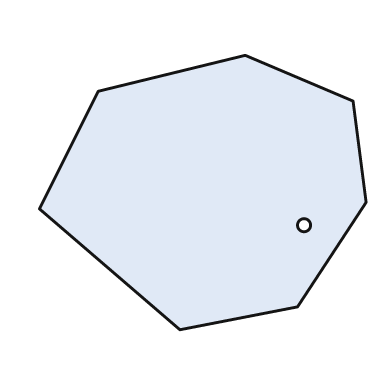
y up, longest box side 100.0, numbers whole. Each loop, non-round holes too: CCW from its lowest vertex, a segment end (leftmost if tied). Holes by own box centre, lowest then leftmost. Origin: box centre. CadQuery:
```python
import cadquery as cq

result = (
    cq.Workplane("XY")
    .moveTo(-7.0, -42.0)
    .lineTo(29.0, -35.0)
    .lineTo(50.0, -3.0)
    .lineTo(46.0, 28.0)
    .lineTo(13.0, 42.0)
    .lineTo(-32.0, 31.0)
    .lineTo(-50.0, -5.0)
    .close()
    .moveTo(31.0, -10.0)
    .circle(2.0)
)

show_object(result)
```